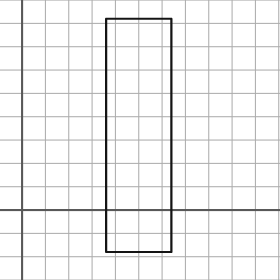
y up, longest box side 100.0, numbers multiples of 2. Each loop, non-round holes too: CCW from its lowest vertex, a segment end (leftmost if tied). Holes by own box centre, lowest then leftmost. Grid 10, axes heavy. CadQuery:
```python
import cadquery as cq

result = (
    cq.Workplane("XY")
    .moveTo(36.0, -18.0)
    .lineTo(64.0, -18.0)
    .lineTo(64.0, 82.0)
    .lineTo(36.0, 82.0)
    .close()
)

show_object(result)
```